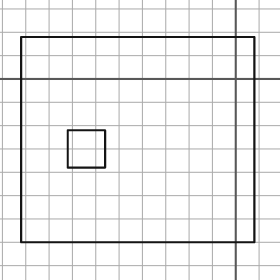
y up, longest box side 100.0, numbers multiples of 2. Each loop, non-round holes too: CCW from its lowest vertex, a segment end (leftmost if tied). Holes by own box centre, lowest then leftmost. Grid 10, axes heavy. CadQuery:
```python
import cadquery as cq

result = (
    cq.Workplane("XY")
    .moveTo(-92.0, -70.0)
    .lineTo(8.0, -70.0)
    .lineTo(8.0, 18.0)
    .lineTo(-92.0, 18.0)
    .close()
    .moveTo(-72.0, -38.0)
    .lineTo(-56.0, -38.0)
    .lineTo(-56.0, -22.0)
    .lineTo(-72.0, -22.0)
    .close()
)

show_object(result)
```